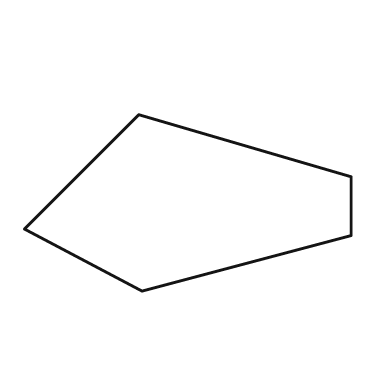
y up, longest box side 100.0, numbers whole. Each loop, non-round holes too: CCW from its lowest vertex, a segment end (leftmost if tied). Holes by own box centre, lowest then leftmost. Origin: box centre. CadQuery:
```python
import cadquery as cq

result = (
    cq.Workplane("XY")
    .moveTo(-14.0, -27.0)
    .lineTo(50.0, -10.0)
    .lineTo(50.0, 8.0)
    .lineTo(-15.0, 27.0)
    .lineTo(-50.0, -8.0)
    .close()
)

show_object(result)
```